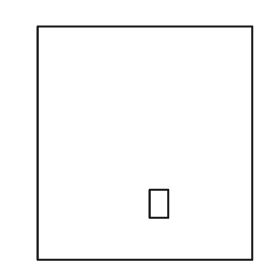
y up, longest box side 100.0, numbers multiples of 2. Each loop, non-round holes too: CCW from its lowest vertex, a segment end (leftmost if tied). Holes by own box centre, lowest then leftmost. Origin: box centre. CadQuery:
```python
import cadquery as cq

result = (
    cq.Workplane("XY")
    .moveTo(-46.0, -50.0)
    .lineTo(46.0, -50.0)
    .lineTo(46.0, 50.0)
    .lineTo(-46.0, 50.0)
    .close()
    .moveTo(2.0, -32.0)
    .lineTo(10.0, -32.0)
    .lineTo(10.0, -20.0)
    .lineTo(2.0, -20.0)
    .close()
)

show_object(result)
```